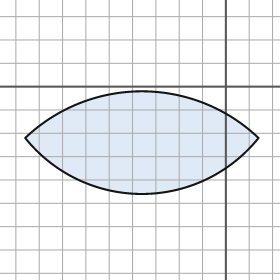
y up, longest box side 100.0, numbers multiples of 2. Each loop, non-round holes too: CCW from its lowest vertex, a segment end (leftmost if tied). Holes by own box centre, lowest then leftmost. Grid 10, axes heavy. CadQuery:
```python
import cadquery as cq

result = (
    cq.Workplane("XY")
    .moveTo(-86.0, -22.0)
    .threePointArc((-36.0, -46.0), (14.0, -22.0))
    .threePointArc((-36.0, -2.0), (-86.0, -22.0))
    .close()
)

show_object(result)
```